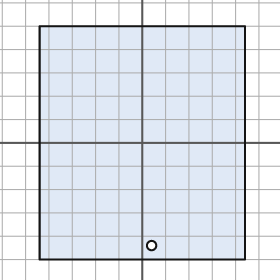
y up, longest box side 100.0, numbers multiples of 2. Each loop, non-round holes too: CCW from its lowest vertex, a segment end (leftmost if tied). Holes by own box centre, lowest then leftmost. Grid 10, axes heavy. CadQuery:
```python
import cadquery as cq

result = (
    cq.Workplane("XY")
    .moveTo(-44.0, -50.0)
    .lineTo(44.0, -50.0)
    .lineTo(44.0, 50.0)
    .lineTo(-44.0, 50.0)
    .close()
    .moveTo(4.0, -44.0)
    .circle(2.0)
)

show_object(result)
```